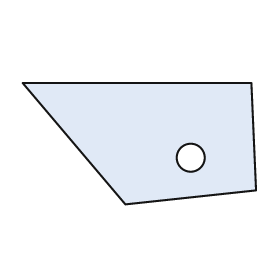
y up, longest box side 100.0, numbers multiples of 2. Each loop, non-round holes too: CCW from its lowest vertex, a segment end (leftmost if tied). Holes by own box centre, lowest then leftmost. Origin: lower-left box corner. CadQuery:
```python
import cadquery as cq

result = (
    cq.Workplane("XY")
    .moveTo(44.0, 0.0)
    .lineTo(100.0, 6.0)
    .lineTo(98.0, 52.0)
    .lineTo(0.0, 52.0)
    .close()
    .moveTo(72.0, 20.0)
    .circle(6.0)
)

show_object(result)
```